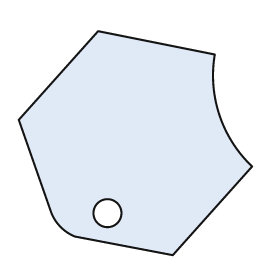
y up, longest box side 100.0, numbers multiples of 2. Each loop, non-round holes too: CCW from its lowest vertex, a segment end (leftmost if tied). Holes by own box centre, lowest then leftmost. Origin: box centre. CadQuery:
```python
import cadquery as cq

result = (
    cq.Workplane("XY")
    .moveTo(16.0, -48.0)
    .lineTo(50.0, -10.0)
    .threePointArc((36.0, 12.0), (34.0, 38.0))
    .lineTo(-16.0, 48.0)
    .lineTo(-50.0, 10.0)
    .lineTo(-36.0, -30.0)
    .threePointArc((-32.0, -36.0), (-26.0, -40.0))
    .close()
    .moveTo(-12.0, -30.0)
    .circle(6.0)
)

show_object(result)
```